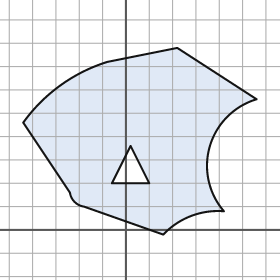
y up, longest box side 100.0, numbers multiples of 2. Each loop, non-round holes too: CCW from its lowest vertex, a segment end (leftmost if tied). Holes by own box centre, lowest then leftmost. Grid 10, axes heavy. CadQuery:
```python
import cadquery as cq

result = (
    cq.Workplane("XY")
    .moveTo(16.0, -2.0)
    .threePointArc((28.0, 6.0), (42.0, 8.0))
    .threePointArc((36.0, 36.0), (56.0, 56.0))
    .lineTo(22.0, 78.0)
    .lineTo(-8.0, 72.0)
    .threePointArc((-28.0, 62.0), (-44.0, 46.0))
    .lineTo(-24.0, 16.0)
    .threePointArc((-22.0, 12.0), (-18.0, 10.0))
    .close()
    .moveTo(-6.0, 20.0)
    .lineTo(10.0, 20.0)
    .lineTo(2.0, 36.0)
    .close()
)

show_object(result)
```